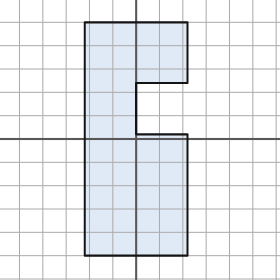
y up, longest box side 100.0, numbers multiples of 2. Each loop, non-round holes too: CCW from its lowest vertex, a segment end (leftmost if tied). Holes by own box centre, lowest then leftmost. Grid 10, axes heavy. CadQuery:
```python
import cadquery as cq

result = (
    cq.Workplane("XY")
    .moveTo(-22.0, -50.0)
    .lineTo(22.0, -50.0)
    .lineTo(22.0, 2.0)
    .lineTo(0.0, 2.0)
    .lineTo(0.0, 24.0)
    .lineTo(22.0, 24.0)
    .lineTo(22.0, 50.0)
    .lineTo(-22.0, 50.0)
    .close()
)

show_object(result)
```